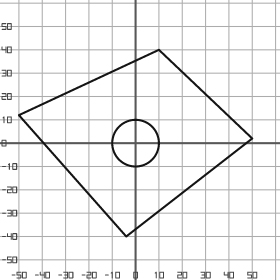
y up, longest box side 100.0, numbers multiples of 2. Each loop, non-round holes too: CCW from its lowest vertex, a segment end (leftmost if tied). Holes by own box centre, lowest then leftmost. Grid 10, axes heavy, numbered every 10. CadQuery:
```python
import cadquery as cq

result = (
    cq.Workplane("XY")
    .moveTo(-4.0, -40.0)
    .lineTo(50.0, 2.0)
    .lineTo(10.0, 40.0)
    .lineTo(-50.0, 12.0)
    .close()
    .moveTo(0.0, 0.0)
    .circle(10.0)
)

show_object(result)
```